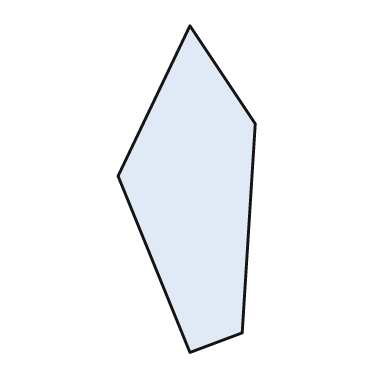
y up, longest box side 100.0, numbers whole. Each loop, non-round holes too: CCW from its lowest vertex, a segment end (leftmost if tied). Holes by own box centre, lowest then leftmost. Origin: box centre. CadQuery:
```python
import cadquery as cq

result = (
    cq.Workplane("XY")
    .moveTo(1.0, -50.0)
    .lineTo(17.0, -44.0)
    .lineTo(21.0, 20.0)
    .lineTo(1.0, 50.0)
    .lineTo(-21.0, 4.0)
    .close()
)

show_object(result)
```